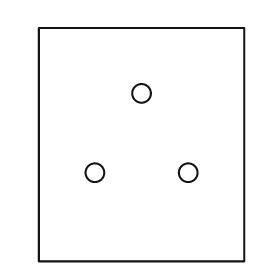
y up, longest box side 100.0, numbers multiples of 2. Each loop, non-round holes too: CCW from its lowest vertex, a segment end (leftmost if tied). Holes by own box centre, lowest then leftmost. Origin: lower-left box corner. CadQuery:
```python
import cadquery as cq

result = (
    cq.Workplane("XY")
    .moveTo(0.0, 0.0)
    .lineTo(88.0, 0.0)
    .lineTo(88.0, 100.0)
    .lineTo(0.0, 100.0)
    .close()
    .moveTo(24.0, 38.0)
    .circle(4.0)
    .moveTo(64.0, 38.0)
    .circle(4.0)
    .moveTo(44.0, 72.0)
    .circle(4.0)
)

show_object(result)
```